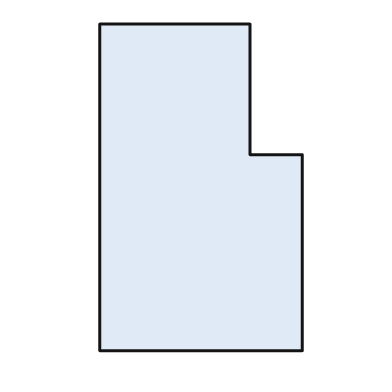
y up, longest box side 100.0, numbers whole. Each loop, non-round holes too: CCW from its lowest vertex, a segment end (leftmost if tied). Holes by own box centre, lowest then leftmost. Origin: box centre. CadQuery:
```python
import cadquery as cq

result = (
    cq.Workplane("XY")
    .moveTo(-31.0, -50.0)
    .lineTo(31.0, -50.0)
    .lineTo(31.0, 10.0)
    .lineTo(15.0, 10.0)
    .lineTo(15.0, 50.0)
    .lineTo(-31.0, 50.0)
    .close()
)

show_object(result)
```